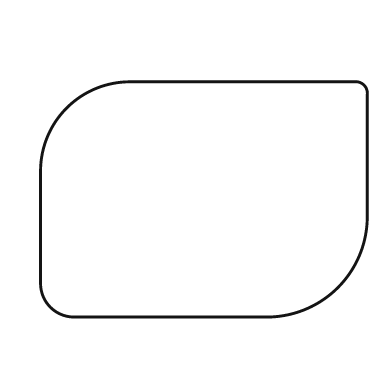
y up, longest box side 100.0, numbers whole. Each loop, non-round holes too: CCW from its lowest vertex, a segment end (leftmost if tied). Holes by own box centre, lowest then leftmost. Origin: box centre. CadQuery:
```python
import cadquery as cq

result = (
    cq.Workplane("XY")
    .moveTo(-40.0, -36.0)
    .lineTo(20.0, -36.0)
    .threePointArc((41.0, -27.0), (50.0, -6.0))
    .lineTo(50.0, 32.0)
    .threePointArc((49.0, 35.0), (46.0, 36.0))
    .lineTo(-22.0, 36.0)
    .threePointArc((-42.0, 28.0), (-50.0, 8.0))
    .lineTo(-50.0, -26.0)
    .threePointArc((-47.0, -33.0), (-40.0, -36.0))
    .close()
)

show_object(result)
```